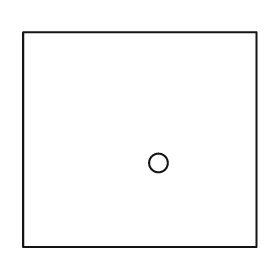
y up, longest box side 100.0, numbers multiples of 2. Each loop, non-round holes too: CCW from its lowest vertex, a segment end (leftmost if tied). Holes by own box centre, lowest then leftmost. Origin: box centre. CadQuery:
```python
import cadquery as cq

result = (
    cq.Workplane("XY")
    .moveTo(-50.0, -46.0)
    .lineTo(50.0, -46.0)
    .lineTo(50.0, 46.0)
    .lineTo(-50.0, 46.0)
    .close()
    .moveTo(8.0, -10.0)
    .circle(4.0)
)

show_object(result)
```